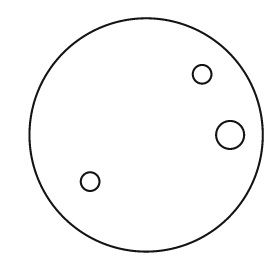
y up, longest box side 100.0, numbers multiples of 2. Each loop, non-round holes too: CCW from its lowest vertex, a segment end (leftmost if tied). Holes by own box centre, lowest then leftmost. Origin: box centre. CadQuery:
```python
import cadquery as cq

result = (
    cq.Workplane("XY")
    .moveTo(0.0, 0.0)
    .circle(50.0)
    .moveTo(-24.0, -20.0)
    .circle(4.0)
    .moveTo(36.0, 0.0)
    .circle(6.0)
    .moveTo(24.0, 26.0)
    .circle(4.0)
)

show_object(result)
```